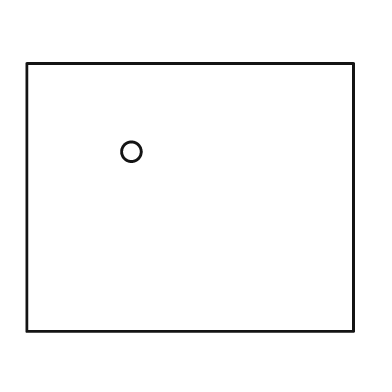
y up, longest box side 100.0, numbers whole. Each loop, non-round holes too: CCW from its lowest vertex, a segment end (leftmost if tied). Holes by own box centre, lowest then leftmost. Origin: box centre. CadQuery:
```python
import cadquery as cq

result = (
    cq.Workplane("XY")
    .moveTo(-50.0, -41.0)
    .lineTo(50.0, -41.0)
    .lineTo(50.0, 41.0)
    .lineTo(-50.0, 41.0)
    .close()
    .moveTo(-18.0, 14.0)
    .circle(3.0)
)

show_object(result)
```